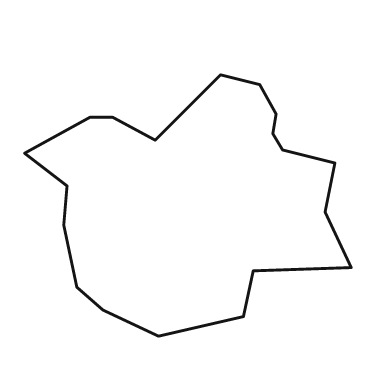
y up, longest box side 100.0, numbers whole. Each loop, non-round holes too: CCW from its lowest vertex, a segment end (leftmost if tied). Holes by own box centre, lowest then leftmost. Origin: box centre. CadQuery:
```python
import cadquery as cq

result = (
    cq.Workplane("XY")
    .moveTo(-9.0, -40.0)
    .lineTo(17.0, -34.0)
    .lineTo(20.0, -20.0)
    .lineTo(50.0, -19.0)
    .lineTo(42.0, -2.0)
    .lineTo(45.0, 13.0)
    .lineTo(29.0, 17.0)
    .lineTo(26.0, 22.0)
    .lineTo(27.0, 28.0)
    .lineTo(22.0, 37.0)
    .lineTo(10.0, 40.0)
    .lineTo(-10.0, 20.0)
    .lineTo(-23.0, 27.0)
    .lineTo(-30.0, 27.0)
    .lineTo(-50.0, 16.0)
    .lineTo(-37.0, 6.0)
    .lineTo(-38.0, -6.0)
    .lineTo(-34.0, -25.0)
    .lineTo(-26.0, -32.0)
    .close()
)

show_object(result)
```